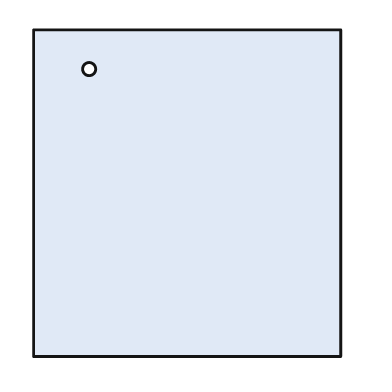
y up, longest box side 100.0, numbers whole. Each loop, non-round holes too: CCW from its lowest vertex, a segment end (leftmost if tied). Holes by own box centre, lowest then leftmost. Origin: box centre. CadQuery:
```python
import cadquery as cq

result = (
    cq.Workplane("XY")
    .moveTo(-47.0, -50.0)
    .lineTo(47.0, -50.0)
    .lineTo(47.0, 50.0)
    .lineTo(-47.0, 50.0)
    .close()
    .moveTo(-30.0, 38.0)
    .circle(2.0)
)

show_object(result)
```